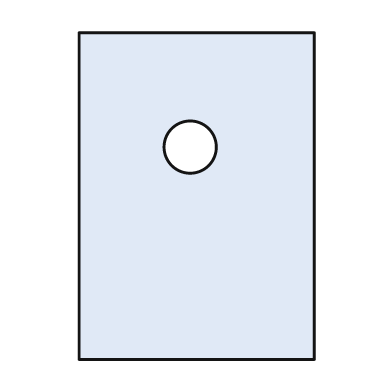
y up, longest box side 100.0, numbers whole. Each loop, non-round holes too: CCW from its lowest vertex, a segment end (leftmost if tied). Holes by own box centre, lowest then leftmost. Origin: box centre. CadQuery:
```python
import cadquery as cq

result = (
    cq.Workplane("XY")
    .moveTo(-36.0, -50.0)
    .lineTo(36.0, -50.0)
    .lineTo(36.0, 50.0)
    .lineTo(-36.0, 50.0)
    .close()
    .moveTo(-2.0, 15.0)
    .circle(8.0)
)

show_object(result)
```